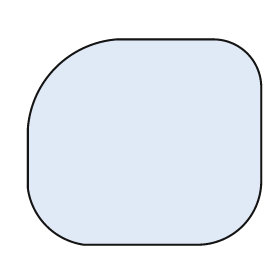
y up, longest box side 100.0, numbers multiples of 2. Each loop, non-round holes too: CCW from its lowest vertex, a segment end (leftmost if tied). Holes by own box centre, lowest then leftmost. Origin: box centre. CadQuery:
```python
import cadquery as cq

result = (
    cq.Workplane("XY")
    .moveTo(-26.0, -44.0)
    .lineTo(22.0, -44.0)
    .threePointArc((42.0, -36.0), (50.0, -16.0))
    .lineTo(50.0, 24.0)
    .threePointArc((44.0, 38.0), (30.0, 44.0))
    .lineTo(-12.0, 44.0)
    .threePointArc((-38.0, 32.0), (-50.0, 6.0))
    .lineTo(-50.0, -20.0)
    .threePointArc((-42.0, -36.0), (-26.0, -44.0))
    .close()
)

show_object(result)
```